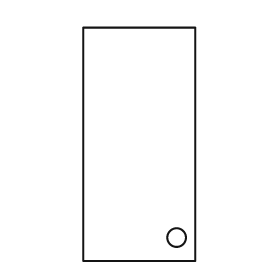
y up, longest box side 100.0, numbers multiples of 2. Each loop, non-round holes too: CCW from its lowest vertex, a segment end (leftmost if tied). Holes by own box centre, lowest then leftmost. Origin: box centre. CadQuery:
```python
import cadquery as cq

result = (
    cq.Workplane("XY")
    .moveTo(-24.0, -50.0)
    .lineTo(24.0, -50.0)
    .lineTo(24.0, 50.0)
    .lineTo(-24.0, 50.0)
    .close()
    .moveTo(16.0, -40.0)
    .circle(4.0)
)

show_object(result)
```